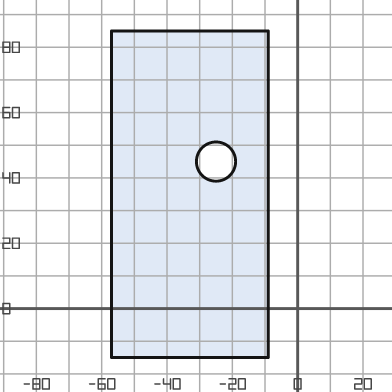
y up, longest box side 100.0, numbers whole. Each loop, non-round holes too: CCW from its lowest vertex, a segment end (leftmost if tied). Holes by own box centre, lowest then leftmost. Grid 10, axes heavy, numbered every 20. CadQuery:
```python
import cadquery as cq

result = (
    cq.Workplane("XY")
    .moveTo(-57.0, -15.0)
    .lineTo(-9.0, -15.0)
    .lineTo(-9.0, 85.0)
    .lineTo(-57.0, 85.0)
    .close()
    .moveTo(-25.0, 45.0)
    .circle(6.0)
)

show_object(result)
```